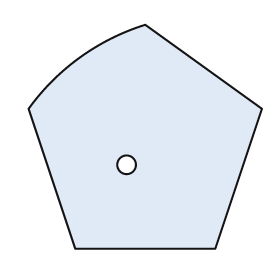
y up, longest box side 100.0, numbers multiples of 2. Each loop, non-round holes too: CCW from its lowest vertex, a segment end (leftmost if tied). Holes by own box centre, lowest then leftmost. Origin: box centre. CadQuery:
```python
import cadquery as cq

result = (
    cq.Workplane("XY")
    .moveTo(-30.0, -48.0)
    .lineTo(30.0, -48.0)
    .lineTo(50.0, 12.0)
    .lineTo(0.0, 48.0)
    .threePointArc((-28.0, 34.0), (-50.0, 12.0))
    .close()
    .moveTo(-8.0, -12.0)
    .circle(4.0)
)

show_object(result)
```